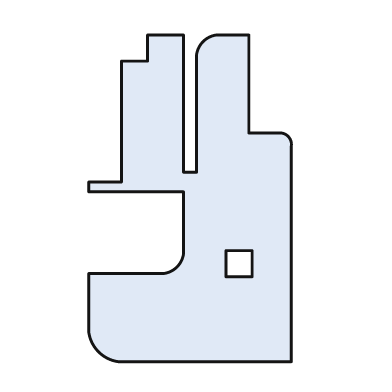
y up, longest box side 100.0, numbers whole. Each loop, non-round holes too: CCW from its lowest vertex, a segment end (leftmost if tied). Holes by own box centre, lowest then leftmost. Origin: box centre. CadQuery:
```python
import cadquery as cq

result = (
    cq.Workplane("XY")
    .moveTo(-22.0, -50.0)
    .lineTo(31.0, -50.0)
    .lineTo(31.0, 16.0)
    .threePointArc((30.0, 19.0), (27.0, 20.0))
    .lineTo(18.0, 20.0)
    .lineTo(18.0, 50.0)
    .lineTo(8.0, 50.0)
    .threePointArc((4.0, 48.0), (2.0, 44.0))
    .lineTo(2.0, 8.0)
    .lineTo(-2.0, 8.0)
    .lineTo(-2.0, 50.0)
    .lineTo(-13.0, 50.0)
    .lineTo(-13.0, 42.0)
    .lineTo(-21.0, 42.0)
    .lineTo(-21.0, 5.0)
    .lineTo(-31.0, 5.0)
    .lineTo(-31.0, 2.0)
    .lineTo(-2.0, 2.0)
    .lineTo(-2.0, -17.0)
    .threePointArc((-4.0, -21.0), (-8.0, -23.0))
    .lineTo(-31.0, -23.0)
    .lineTo(-31.0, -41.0)
    .threePointArc((-28.0, -47.0), (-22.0, -50.0))
    .close()
    .moveTo(11.0, -24.0)
    .lineTo(19.0, -24.0)
    .lineTo(19.0, -16.0)
    .lineTo(11.0, -16.0)
    .close()
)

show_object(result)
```